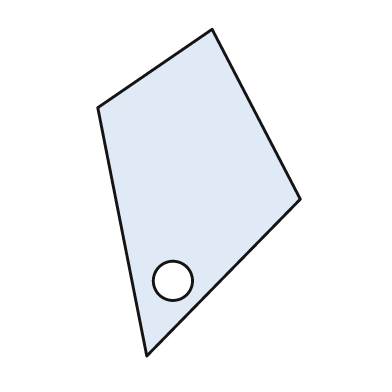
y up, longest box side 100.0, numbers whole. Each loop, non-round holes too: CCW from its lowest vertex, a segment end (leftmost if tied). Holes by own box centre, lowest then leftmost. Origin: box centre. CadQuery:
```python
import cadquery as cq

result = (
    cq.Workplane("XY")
    .moveTo(-16.0, -50.0)
    .lineTo(31.0, -2.0)
    .lineTo(4.0, 50.0)
    .lineTo(-31.0, 26.0)
    .close()
    .moveTo(-8.0, -27.0)
    .circle(6.0)
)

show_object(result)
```